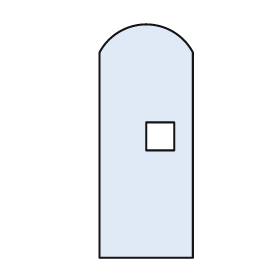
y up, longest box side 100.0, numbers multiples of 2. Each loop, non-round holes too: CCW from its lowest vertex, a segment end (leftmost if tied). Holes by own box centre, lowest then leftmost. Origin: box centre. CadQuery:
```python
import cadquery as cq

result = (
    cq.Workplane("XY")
    .moveTo(-20.0, -50.0)
    .lineTo(20.0, -50.0)
    .lineTo(20.0, 38.0)
    .threePointArc((0.0, 50.0), (-20.0, 38.0))
    .close()
    .moveTo(0.0, -4.0)
    .lineTo(12.0, -4.0)
    .lineTo(12.0, 8.0)
    .lineTo(0.0, 8.0)
    .close()
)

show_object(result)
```